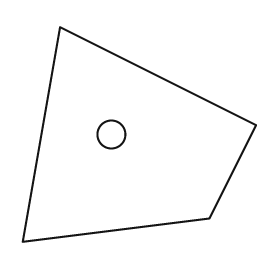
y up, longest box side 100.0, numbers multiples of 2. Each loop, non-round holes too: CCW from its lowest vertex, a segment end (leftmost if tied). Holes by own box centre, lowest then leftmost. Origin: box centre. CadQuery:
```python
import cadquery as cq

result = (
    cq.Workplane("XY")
    .moveTo(-50.0, -46.0)
    .lineTo(30.0, -36.0)
    .lineTo(50.0, 4.0)
    .lineTo(-34.0, 46.0)
    .close()
    .moveTo(-12.0, 0.0)
    .circle(6.0)
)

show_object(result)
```